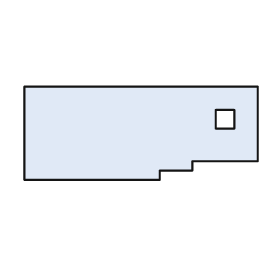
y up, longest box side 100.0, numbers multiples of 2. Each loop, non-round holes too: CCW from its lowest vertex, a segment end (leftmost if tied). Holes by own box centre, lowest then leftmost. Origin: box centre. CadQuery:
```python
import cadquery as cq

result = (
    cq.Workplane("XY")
    .moveTo(-50.0, -20.0)
    .lineTo(8.0, -20.0)
    .lineTo(8.0, -16.0)
    .lineTo(22.0, -16.0)
    .lineTo(22.0, -12.0)
    .lineTo(50.0, -12.0)
    .lineTo(50.0, 20.0)
    .lineTo(-50.0, 20.0)
    .close()
    .moveTo(32.0, 2.0)
    .lineTo(40.0, 2.0)
    .lineTo(40.0, 10.0)
    .lineTo(32.0, 10.0)
    .close()
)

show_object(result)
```